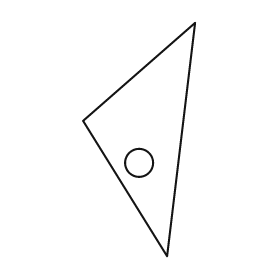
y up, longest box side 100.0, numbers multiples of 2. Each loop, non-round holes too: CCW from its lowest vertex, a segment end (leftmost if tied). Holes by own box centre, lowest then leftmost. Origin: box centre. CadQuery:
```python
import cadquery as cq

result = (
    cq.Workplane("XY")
    .moveTo(12.0, -50.0)
    .lineTo(24.0, 50.0)
    .lineTo(-24.0, 8.0)
    .close()
    .moveTo(0.0, -10.0)
    .circle(6.0)
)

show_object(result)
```